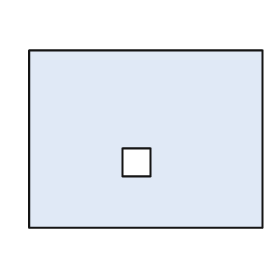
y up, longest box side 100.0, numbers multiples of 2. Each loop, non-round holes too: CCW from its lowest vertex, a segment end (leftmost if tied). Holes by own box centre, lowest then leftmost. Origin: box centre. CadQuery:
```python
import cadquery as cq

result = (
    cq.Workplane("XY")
    .moveTo(-50.0, -38.0)
    .lineTo(50.0, -38.0)
    .lineTo(50.0, 38.0)
    .lineTo(-50.0, 38.0)
    .close()
    .moveTo(-10.0, -16.0)
    .lineTo(2.0, -16.0)
    .lineTo(2.0, -4.0)
    .lineTo(-10.0, -4.0)
    .close()
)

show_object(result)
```